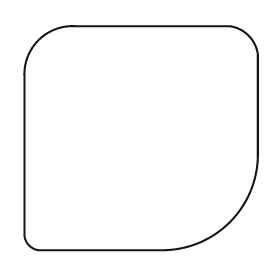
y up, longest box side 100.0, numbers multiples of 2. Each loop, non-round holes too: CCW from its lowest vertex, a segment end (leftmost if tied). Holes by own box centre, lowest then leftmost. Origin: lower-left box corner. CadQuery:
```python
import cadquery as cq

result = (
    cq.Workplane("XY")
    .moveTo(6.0, 0.0)
    .lineTo(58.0, 0.0)
    .threePointArc((88.0, 12.0), (100.0, 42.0))
    .lineTo(100.0, 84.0)
    .threePointArc((96.0, 92.0), (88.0, 96.0))
    .lineTo(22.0, 96.0)
    .threePointArc((6.0, 90.0), (0.0, 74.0))
    .lineTo(0.0, 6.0)
    .threePointArc((2.0, 2.0), (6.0, 0.0))
    .close()
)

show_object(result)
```